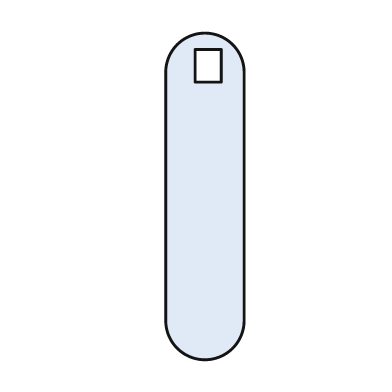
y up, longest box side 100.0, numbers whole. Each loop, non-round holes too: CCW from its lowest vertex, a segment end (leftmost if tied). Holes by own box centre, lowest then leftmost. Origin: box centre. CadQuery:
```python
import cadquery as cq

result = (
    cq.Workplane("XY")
    .moveTo(-12.0, -38.0)
    .threePointArc((0.0, -50.0), (12.0, -38.0))
    .lineTo(12.0, 38.0)
    .threePointArc((0.0, 50.0), (-12.0, 38.0))
    .close()
    .moveTo(-3.0, 35.0)
    .lineTo(5.0, 35.0)
    .lineTo(5.0, 45.0)
    .lineTo(-3.0, 45.0)
    .close()
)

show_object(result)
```